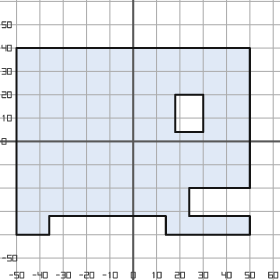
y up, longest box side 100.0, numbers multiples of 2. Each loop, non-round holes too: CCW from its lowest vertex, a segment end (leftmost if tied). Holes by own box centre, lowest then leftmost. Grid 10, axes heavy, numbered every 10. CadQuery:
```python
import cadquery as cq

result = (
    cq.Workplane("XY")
    .moveTo(-50.0, -40.0)
    .lineTo(-36.0, -40.0)
    .lineTo(-36.0, -32.0)
    .lineTo(14.0, -32.0)
    .lineTo(14.0, -40.0)
    .lineTo(50.0, -40.0)
    .lineTo(50.0, -32.0)
    .lineTo(24.0, -32.0)
    .lineTo(24.0, -20.0)
    .lineTo(50.0, -20.0)
    .lineTo(50.0, 40.0)
    .lineTo(-50.0, 40.0)
    .close()
    .moveTo(18.0, 4.0)
    .lineTo(30.0, 4.0)
    .lineTo(30.0, 20.0)
    .lineTo(18.0, 20.0)
    .close()
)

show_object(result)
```